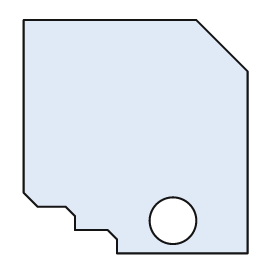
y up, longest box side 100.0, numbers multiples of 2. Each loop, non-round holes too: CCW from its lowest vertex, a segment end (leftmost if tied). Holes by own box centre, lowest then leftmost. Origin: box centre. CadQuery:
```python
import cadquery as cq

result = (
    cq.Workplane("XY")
    .moveTo(-8.0, -50.0)
    .lineTo(48.0, -50.0)
    .lineTo(48.0, 28.0)
    .lineTo(26.0, 50.0)
    .lineTo(-48.0, 50.0)
    .lineTo(-48.0, -24.0)
    .lineTo(-42.0, -30.0)
    .lineTo(-30.0, -30.0)
    .lineTo(-26.0, -34.0)
    .lineTo(-26.0, -40.0)
    .lineTo(-12.0, -40.0)
    .lineTo(-8.0, -44.0)
    .close()
    .moveTo(16.0, -36.0)
    .circle(10.0)
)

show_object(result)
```